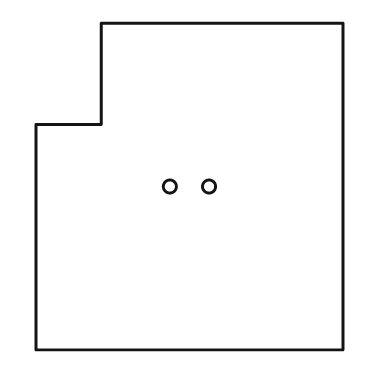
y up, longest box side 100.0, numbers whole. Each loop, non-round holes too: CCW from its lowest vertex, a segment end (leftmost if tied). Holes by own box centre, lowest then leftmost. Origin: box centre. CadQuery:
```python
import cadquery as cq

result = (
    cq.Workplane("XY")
    .moveTo(-47.0, -50.0)
    .lineTo(47.0, -50.0)
    .lineTo(47.0, 50.0)
    .lineTo(-27.0, 50.0)
    .lineTo(-27.0, 19.0)
    .lineTo(-47.0, 19.0)
    .close()
    .moveTo(-6.0, 0.0)
    .circle(2.0)
    .moveTo(6.0, 0.0)
    .circle(2.0)
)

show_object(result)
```